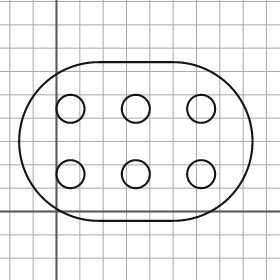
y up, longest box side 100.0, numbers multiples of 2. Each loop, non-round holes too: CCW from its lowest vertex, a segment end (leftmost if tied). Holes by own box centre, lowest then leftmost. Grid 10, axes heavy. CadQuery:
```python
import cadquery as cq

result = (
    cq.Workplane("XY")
    .moveTo(18.0, -4.0)
    .lineTo(50.0, -4.0)
    .threePointArc((84.0, 30.0), (50.0, 64.0))
    .lineTo(18.0, 64.0)
    .threePointArc((-16.0, 30.0), (18.0, -4.0))
    .close()
    .moveTo(6.0, 16.0)
    .circle(6.0)
    .moveTo(34.0, 16.0)
    .circle(6.0)
    .moveTo(62.0, 16.0)
    .circle(6.0)
    .moveTo(6.0, 44.0)
    .circle(6.0)
    .moveTo(34.0, 44.0)
    .circle(6.0)
    .moveTo(62.0, 44.0)
    .circle(6.0)
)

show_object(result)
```